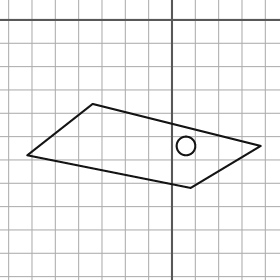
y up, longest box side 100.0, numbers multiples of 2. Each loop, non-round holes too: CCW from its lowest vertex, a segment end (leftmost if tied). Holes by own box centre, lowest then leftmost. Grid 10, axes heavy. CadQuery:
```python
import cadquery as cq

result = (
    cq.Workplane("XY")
    .moveTo(8.0, -72.0)
    .lineTo(38.0, -54.0)
    .lineTo(-34.0, -36.0)
    .lineTo(-62.0, -58.0)
    .close()
    .moveTo(6.0, -54.0)
    .circle(4.0)
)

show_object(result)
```